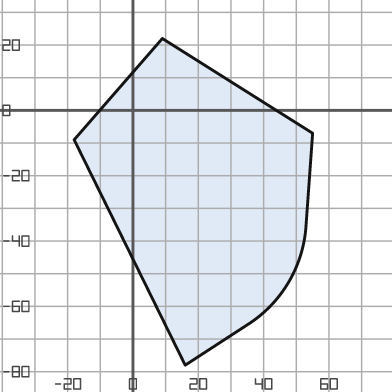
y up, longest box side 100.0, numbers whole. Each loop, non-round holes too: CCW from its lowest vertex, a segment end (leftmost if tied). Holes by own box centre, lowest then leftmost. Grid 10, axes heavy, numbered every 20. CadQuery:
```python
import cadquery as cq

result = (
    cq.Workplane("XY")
    .moveTo(16.0, -78.0)
    .lineTo(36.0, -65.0)
    .threePointArc((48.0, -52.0), (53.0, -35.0))
    .lineTo(55.0, -7.0)
    .lineTo(9.0, 22.0)
    .lineTo(-18.0, -9.0)
    .close()
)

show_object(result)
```